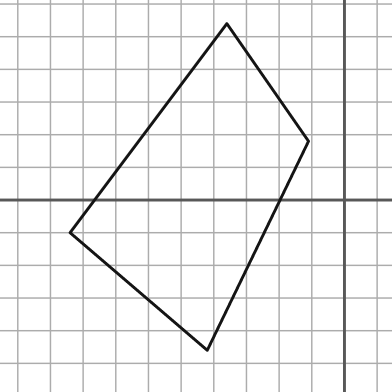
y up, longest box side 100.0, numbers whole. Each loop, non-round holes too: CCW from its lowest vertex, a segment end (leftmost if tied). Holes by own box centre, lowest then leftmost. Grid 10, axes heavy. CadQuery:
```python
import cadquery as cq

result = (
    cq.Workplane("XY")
    .moveTo(-42.0, -46.0)
    .lineTo(-11.0, 18.0)
    .lineTo(-36.0, 54.0)
    .lineTo(-84.0, -10.0)
    .close()
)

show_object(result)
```